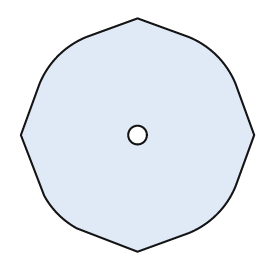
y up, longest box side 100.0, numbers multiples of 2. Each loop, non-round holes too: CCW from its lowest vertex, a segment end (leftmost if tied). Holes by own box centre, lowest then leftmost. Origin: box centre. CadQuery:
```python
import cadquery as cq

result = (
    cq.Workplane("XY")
    .moveTo(0.0, -50.0)
    .lineTo(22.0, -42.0)
    .threePointArc((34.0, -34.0), (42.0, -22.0))
    .lineTo(50.0, 0.0)
    .lineTo(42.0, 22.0)
    .threePointArc((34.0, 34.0), (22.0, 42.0))
    .lineTo(0.0, 50.0)
    .lineTo(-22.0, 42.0)
    .threePointArc((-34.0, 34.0), (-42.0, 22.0))
    .lineTo(-50.0, 0.0)
    .lineTo(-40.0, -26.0)
    .threePointArc((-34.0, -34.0), (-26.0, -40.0))
    .close()
    .moveTo(0.0, 0.0)
    .circle(4.0)
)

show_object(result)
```